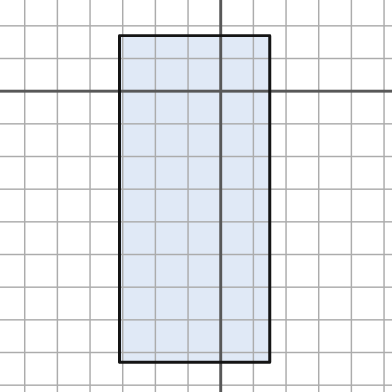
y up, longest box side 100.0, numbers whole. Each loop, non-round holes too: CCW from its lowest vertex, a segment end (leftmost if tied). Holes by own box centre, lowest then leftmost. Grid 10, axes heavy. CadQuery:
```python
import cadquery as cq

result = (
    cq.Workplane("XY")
    .moveTo(-31.0, -83.0)
    .lineTo(15.0, -83.0)
    .lineTo(15.0, 17.0)
    .lineTo(-31.0, 17.0)
    .close()
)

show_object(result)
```